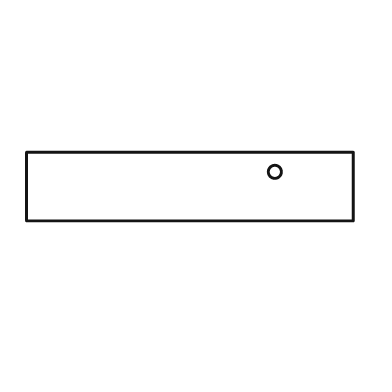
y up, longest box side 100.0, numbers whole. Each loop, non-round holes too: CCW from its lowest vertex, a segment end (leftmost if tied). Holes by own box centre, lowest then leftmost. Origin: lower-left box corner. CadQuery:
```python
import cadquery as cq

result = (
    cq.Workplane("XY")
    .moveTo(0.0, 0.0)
    .lineTo(100.0, 0.0)
    .lineTo(100.0, 21.0)
    .lineTo(0.0, 21.0)
    .close()
    .moveTo(76.0, 15.0)
    .circle(2.0)
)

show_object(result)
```